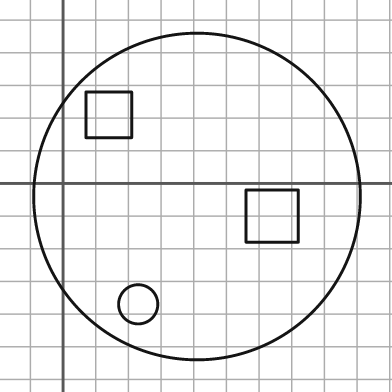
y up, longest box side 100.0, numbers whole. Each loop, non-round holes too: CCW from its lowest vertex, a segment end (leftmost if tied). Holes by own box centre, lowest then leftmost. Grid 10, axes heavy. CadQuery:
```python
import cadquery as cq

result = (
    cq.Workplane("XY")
    .moveTo(41.0, -4.0)
    .circle(50.0)
    .moveTo(23.0, -37.0)
    .circle(6.0)
    .moveTo(56.0, -18.0)
    .lineTo(72.0, -18.0)
    .lineTo(72.0, -2.0)
    .lineTo(56.0, -2.0)
    .close()
    .moveTo(7.0, 14.0)
    .lineTo(21.0, 14.0)
    .lineTo(21.0, 28.0)
    .lineTo(7.0, 28.0)
    .close()
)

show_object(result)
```